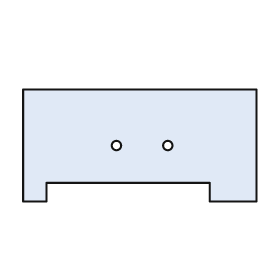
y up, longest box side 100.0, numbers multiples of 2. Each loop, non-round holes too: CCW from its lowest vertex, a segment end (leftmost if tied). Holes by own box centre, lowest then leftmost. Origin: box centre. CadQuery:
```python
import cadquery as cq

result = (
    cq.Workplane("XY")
    .moveTo(-50.0, -24.0)
    .lineTo(-40.0, -24.0)
    .lineTo(-40.0, -16.0)
    .lineTo(30.0, -16.0)
    .lineTo(30.0, -24.0)
    .lineTo(50.0, -24.0)
    .lineTo(50.0, 24.0)
    .lineTo(-50.0, 24.0)
    .close()
    .moveTo(-10.0, 0.0)
    .circle(2.0)
    .moveTo(12.0, 0.0)
    .circle(2.0)
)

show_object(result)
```